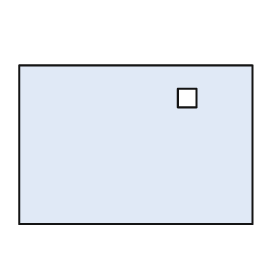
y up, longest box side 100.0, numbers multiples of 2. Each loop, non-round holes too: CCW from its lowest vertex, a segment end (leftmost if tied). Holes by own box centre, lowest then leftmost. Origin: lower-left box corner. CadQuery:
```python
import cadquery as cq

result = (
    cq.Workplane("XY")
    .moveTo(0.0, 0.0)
    .lineTo(100.0, 0.0)
    .lineTo(100.0, 68.0)
    .lineTo(0.0, 68.0)
    .close()
    .moveTo(68.0, 50.0)
    .lineTo(76.0, 50.0)
    .lineTo(76.0, 58.0)
    .lineTo(68.0, 58.0)
    .close()
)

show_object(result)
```